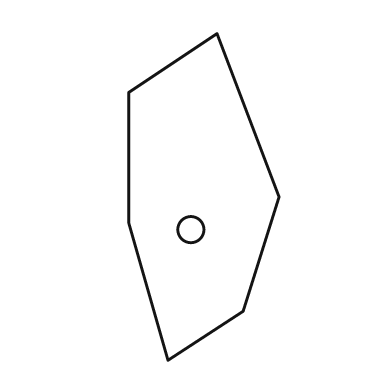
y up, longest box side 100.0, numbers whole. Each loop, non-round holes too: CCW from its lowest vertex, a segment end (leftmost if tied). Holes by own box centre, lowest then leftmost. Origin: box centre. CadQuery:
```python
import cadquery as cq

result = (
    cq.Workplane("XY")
    .moveTo(-11.0, -50.0)
    .lineTo(12.0, -35.0)
    .lineTo(23.0, 0.0)
    .lineTo(4.0, 50.0)
    .lineTo(-23.0, 32.0)
    .lineTo(-23.0, -8.0)
    .close()
    .moveTo(-4.0, -10.0)
    .circle(4.0)
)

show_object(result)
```